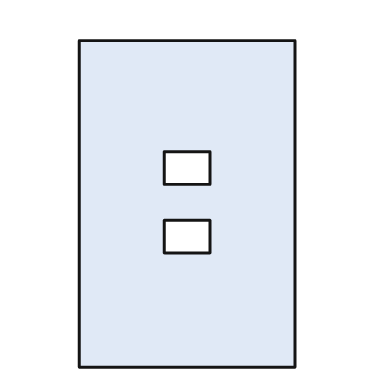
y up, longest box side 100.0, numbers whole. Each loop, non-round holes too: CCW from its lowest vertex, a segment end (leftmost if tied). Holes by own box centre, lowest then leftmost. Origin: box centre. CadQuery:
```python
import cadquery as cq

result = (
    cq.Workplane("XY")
    .moveTo(-33.0, -50.0)
    .lineTo(33.0, -50.0)
    .lineTo(33.0, 50.0)
    .lineTo(-33.0, 50.0)
    .close()
    .moveTo(-7.0, -15.0)
    .lineTo(7.0, -15.0)
    .lineTo(7.0, -5.0)
    .lineTo(-7.0, -5.0)
    .close()
    .moveTo(-7.0, 6.0)
    .lineTo(7.0, 6.0)
    .lineTo(7.0, 16.0)
    .lineTo(-7.0, 16.0)
    .close()
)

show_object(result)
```